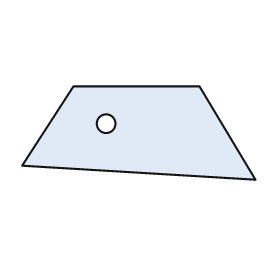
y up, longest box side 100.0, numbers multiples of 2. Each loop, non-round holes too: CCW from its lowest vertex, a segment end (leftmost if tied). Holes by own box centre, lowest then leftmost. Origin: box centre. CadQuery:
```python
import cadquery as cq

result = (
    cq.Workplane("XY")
    .moveTo(50.0, -20.0)
    .lineTo(26.0, 20.0)
    .lineTo(-28.0, 20.0)
    .lineTo(-50.0, -14.0)
    .close()
    .moveTo(-14.0, 4.0)
    .circle(4.0)
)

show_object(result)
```